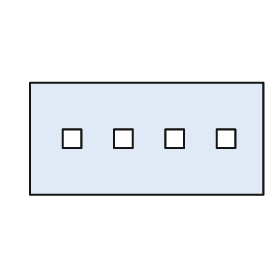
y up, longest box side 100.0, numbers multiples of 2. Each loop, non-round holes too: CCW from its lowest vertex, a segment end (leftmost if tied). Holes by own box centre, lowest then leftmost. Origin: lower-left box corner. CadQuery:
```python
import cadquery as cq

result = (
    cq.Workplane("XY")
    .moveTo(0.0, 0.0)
    .lineTo(100.0, 0.0)
    .lineTo(100.0, 48.0)
    .lineTo(0.0, 48.0)
    .close()
    .moveTo(14.0, 20.0)
    .lineTo(22.0, 20.0)
    .lineTo(22.0, 28.0)
    .lineTo(14.0, 28.0)
    .close()
    .moveTo(36.0, 20.0)
    .lineTo(44.0, 20.0)
    .lineTo(44.0, 28.0)
    .lineTo(36.0, 28.0)
    .close()
    .moveTo(58.0, 20.0)
    .lineTo(66.0, 20.0)
    .lineTo(66.0, 28.0)
    .lineTo(58.0, 28.0)
    .close()
    .moveTo(80.0, 20.0)
    .lineTo(88.0, 20.0)
    .lineTo(88.0, 28.0)
    .lineTo(80.0, 28.0)
    .close()
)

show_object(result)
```